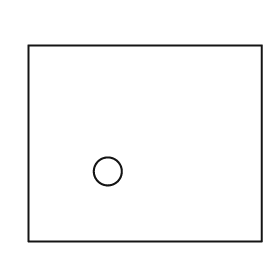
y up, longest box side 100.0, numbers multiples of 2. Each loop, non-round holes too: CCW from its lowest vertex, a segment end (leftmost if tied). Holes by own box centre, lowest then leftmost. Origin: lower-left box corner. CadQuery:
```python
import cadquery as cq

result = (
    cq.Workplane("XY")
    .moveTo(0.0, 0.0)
    .lineTo(100.0, 0.0)
    .lineTo(100.0, 84.0)
    .lineTo(0.0, 84.0)
    .close()
    .moveTo(34.0, 30.0)
    .circle(6.0)
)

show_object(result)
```